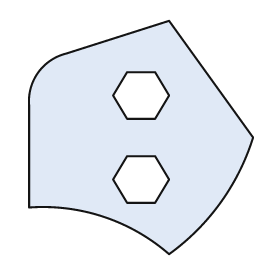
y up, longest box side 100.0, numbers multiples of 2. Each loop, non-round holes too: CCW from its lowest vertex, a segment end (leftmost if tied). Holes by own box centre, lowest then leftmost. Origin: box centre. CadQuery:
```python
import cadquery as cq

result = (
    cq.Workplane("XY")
    .moveTo(12.0, -50.0)
    .threePointArc((34.0, -28.0), (48.0, 0.0))
    .lineTo(12.0, 50.0)
    .lineTo(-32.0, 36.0)
    .threePointArc((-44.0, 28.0), (-48.0, 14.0))
    .lineTo(-48.0, -30.0)
    .threePointArc((-16.0, -34.0), (12.0, -50.0))
    .close()
    .moveTo(-6.0, -28.0)
    .lineTo(6.0, -28.0)
    .lineTo(12.0, -18.0)
    .lineTo(6.0, -8.0)
    .lineTo(-6.0, -8.0)
    .lineTo(-12.0, -18.0)
    .close()
    .moveTo(-6.0, 8.0)
    .lineTo(6.0, 8.0)
    .lineTo(12.0, 18.0)
    .lineTo(6.0, 28.0)
    .lineTo(-6.0, 28.0)
    .lineTo(-12.0, 18.0)
    .close()
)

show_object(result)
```